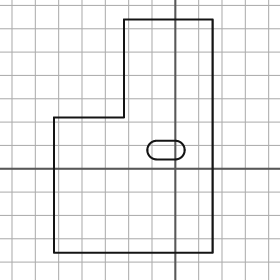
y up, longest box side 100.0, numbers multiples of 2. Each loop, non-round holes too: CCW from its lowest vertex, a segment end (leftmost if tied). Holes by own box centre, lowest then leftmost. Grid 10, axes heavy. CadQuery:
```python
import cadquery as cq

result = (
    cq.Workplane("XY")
    .moveTo(-52.0, -36.0)
    .lineTo(16.0, -36.0)
    .lineTo(16.0, 64.0)
    .lineTo(-22.0, 64.0)
    .lineTo(-22.0, 22.0)
    .lineTo(-52.0, 22.0)
    .close()
    .moveTo(-8.0, 4.0)
    .lineTo(0.0, 4.0)
    .threePointArc((4.0, 8.0), (0.0, 12.0))
    .lineTo(-8.0, 12.0)
    .threePointArc((-12.0, 8.0), (-8.0, 4.0))
    .close()
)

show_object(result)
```